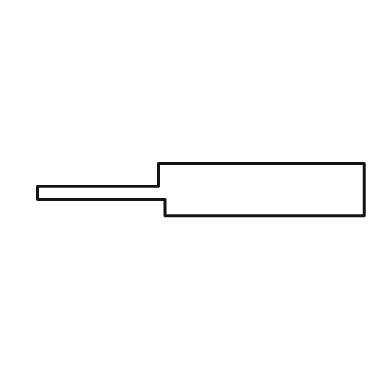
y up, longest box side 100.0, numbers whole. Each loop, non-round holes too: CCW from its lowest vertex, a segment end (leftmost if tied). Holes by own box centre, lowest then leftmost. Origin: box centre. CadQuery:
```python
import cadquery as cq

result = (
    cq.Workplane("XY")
    .moveTo(-11.0, -8.0)
    .lineTo(50.0, -8.0)
    .lineTo(50.0, 8.0)
    .lineTo(-13.0, 8.0)
    .lineTo(-13.0, 1.0)
    .lineTo(-50.0, 1.0)
    .lineTo(-50.0, -3.0)
    .lineTo(-11.0, -3.0)
    .close()
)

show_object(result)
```